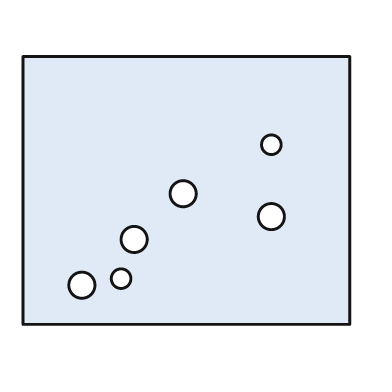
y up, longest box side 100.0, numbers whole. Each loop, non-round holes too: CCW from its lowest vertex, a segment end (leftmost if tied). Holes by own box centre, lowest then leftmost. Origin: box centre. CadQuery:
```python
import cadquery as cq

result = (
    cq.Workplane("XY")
    .moveTo(-50.0, -41.0)
    .lineTo(50.0, -41.0)
    .lineTo(50.0, 41.0)
    .lineTo(-50.0, 41.0)
    .close()
    .moveTo(-32.0, -29.0)
    .circle(4.0)
    .moveTo(-20.0, -27.0)
    .circle(3.0)
    .moveTo(-16.0, -15.0)
    .circle(4.0)
    .moveTo(26.0, -8.0)
    .circle(4.0)
    .moveTo(-1.0, -1.0)
    .circle(4.0)
    .moveTo(26.0, 14.0)
    .circle(3.0)
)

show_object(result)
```